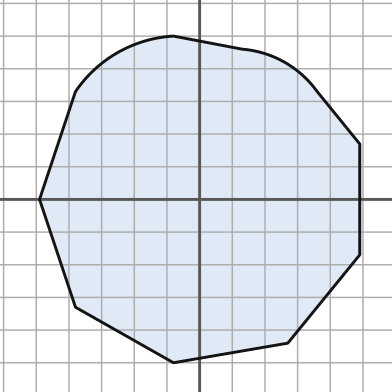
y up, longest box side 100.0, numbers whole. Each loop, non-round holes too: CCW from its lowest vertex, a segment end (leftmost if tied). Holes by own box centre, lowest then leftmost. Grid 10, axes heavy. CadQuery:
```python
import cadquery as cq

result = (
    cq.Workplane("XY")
    .moveTo(-8.0, -50.0)
    .lineTo(27.0, -44.0)
    .lineTo(49.0, -17.0)
    .lineTo(49.0, 17.0)
    .lineTo(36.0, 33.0)
    .threePointArc((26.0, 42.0), (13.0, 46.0))
    .lineTo(-8.0, 50.0)
    .threePointArc((-25.0, 45.0), (-38.0, 33.0))
    .lineTo(-49.0, 0.0)
    .lineTo(-38.0, -33.0)
    .close()
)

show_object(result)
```